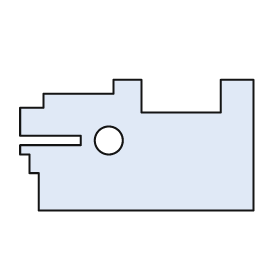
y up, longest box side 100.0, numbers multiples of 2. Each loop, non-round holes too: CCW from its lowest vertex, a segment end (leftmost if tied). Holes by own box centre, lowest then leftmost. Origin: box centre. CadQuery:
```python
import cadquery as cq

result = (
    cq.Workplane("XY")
    .moveTo(-42.0, -28.0)
    .lineTo(50.0, -28.0)
    .lineTo(50.0, 28.0)
    .lineTo(36.0, 28.0)
    .lineTo(36.0, 14.0)
    .lineTo(2.0, 14.0)
    .lineTo(2.0, 28.0)
    .lineTo(-10.0, 28.0)
    .lineTo(-10.0, 22.0)
    .lineTo(-40.0, 22.0)
    .lineTo(-40.0, 16.0)
    .lineTo(-50.0, 16.0)
    .lineTo(-50.0, 4.0)
    .lineTo(-24.0, 4.0)
    .lineTo(-24.0, 0.0)
    .lineTo(-50.0, 0.0)
    .lineTo(-50.0, -4.0)
    .lineTo(-46.0, -4.0)
    .lineTo(-46.0, -12.0)
    .lineTo(-42.0, -12.0)
    .close()
    .moveTo(-12.0, 2.0)
    .circle(6.0)
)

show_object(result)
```